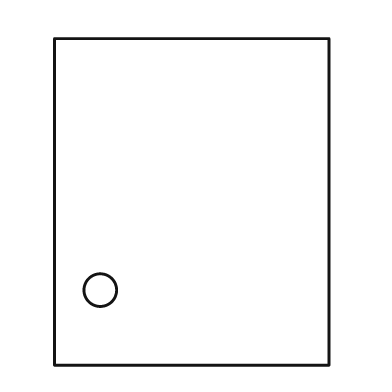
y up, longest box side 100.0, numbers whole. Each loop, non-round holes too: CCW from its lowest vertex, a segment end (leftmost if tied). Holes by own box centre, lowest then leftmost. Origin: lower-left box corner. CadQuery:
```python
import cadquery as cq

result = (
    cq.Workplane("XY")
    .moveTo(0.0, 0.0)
    .lineTo(84.0, 0.0)
    .lineTo(84.0, 100.0)
    .lineTo(0.0, 100.0)
    .close()
    .moveTo(14.0, 23.0)
    .circle(5.0)
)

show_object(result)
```